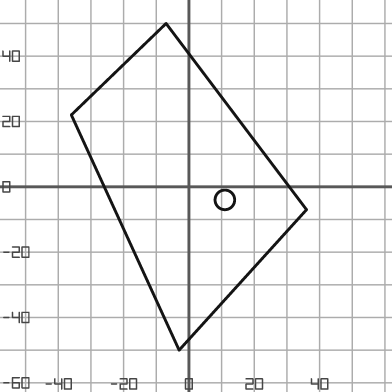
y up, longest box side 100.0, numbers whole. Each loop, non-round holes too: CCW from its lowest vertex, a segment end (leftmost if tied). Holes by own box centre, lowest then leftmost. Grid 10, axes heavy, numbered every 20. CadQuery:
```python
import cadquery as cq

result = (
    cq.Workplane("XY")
    .moveTo(-3.0, -50.0)
    .lineTo(36.0, -7.0)
    .lineTo(-7.0, 50.0)
    .lineTo(-36.0, 22.0)
    .close()
    .moveTo(11.0, -4.0)
    .circle(3.0)
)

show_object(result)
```